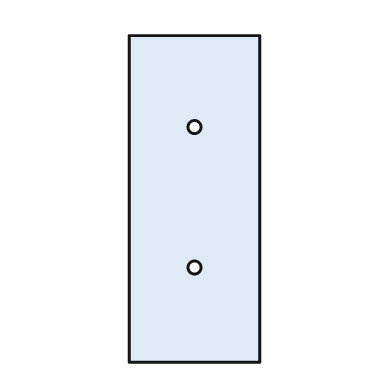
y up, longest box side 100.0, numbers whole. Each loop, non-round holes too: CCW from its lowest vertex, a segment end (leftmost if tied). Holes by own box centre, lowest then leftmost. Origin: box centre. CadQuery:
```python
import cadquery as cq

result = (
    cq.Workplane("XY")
    .moveTo(-20.0, -50.0)
    .lineTo(20.0, -50.0)
    .lineTo(20.0, 50.0)
    .lineTo(-20.0, 50.0)
    .close()
    .moveTo(0.0, -21.0)
    .circle(2.0)
    .moveTo(0.0, 22.0)
    .circle(2.0)
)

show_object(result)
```